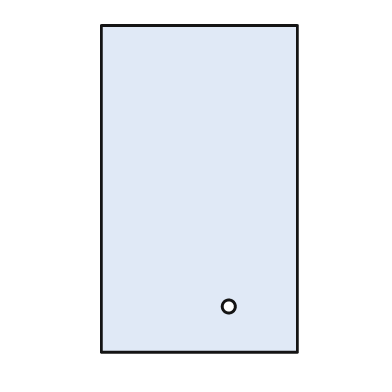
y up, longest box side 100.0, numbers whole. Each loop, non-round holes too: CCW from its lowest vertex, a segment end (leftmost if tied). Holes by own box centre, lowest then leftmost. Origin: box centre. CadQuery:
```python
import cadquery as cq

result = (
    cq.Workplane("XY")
    .moveTo(-30.0, -50.0)
    .lineTo(30.0, -50.0)
    .lineTo(30.0, 50.0)
    .lineTo(-30.0, 50.0)
    .close()
    .moveTo(9.0, -36.0)
    .circle(2.0)
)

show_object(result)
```